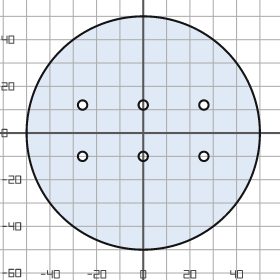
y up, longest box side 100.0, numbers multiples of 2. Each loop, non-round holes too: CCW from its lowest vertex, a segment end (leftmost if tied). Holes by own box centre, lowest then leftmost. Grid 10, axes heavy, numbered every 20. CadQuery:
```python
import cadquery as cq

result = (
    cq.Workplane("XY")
    .moveTo(0.0, 0.0)
    .circle(50.0)
    .moveTo(-26.0, -10.0)
    .circle(2.0)
    .moveTo(0.0, -10.0)
    .circle(2.0)
    .moveTo(26.0, -10.0)
    .circle(2.0)
    .moveTo(-26.0, 12.0)
    .circle(2.0)
    .moveTo(0.0, 12.0)
    .circle(2.0)
    .moveTo(26.0, 12.0)
    .circle(2.0)
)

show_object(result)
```